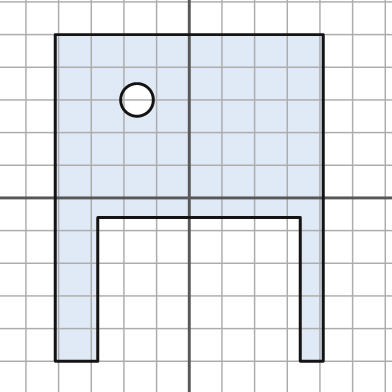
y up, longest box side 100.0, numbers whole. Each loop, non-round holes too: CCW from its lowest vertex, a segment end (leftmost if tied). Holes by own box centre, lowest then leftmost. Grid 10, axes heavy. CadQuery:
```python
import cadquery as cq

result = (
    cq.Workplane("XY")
    .moveTo(-41.0, -50.0)
    .lineTo(-28.0, -50.0)
    .lineTo(-28.0, -6.0)
    .lineTo(34.0, -6.0)
    .lineTo(34.0, -50.0)
    .lineTo(41.0, -50.0)
    .lineTo(41.0, 50.0)
    .lineTo(-41.0, 50.0)
    .close()
    .moveTo(-16.0, 30.0)
    .circle(5.0)
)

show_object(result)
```